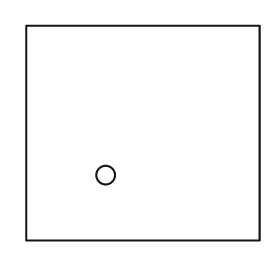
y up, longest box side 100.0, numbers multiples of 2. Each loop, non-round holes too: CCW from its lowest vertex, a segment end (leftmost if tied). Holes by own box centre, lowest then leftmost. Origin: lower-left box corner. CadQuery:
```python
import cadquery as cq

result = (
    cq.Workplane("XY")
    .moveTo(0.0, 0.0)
    .lineTo(100.0, 0.0)
    .lineTo(100.0, 92.0)
    .lineTo(0.0, 92.0)
    .close()
    .moveTo(34.0, 28.0)
    .circle(4.0)
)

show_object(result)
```